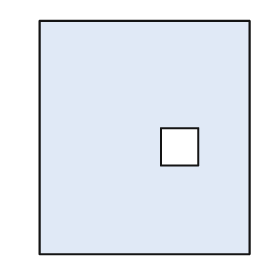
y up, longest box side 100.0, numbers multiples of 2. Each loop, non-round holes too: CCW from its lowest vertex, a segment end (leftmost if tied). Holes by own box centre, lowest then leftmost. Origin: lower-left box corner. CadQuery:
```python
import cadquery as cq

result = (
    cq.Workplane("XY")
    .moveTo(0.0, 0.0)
    .lineTo(90.0, 0.0)
    .lineTo(90.0, 100.0)
    .lineTo(0.0, 100.0)
    .close()
    .moveTo(52.0, 38.0)
    .lineTo(68.0, 38.0)
    .lineTo(68.0, 54.0)
    .lineTo(52.0, 54.0)
    .close()
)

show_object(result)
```